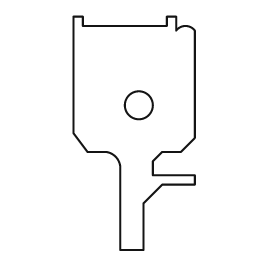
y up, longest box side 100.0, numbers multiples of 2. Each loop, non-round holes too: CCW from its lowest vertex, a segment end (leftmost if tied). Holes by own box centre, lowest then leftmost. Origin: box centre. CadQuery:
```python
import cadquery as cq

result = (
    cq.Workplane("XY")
    .moveTo(-6.0, -50.0)
    .lineTo(4.0, -50.0)
    .lineTo(4.0, -30.0)
    .lineTo(12.0, -22.0)
    .lineTo(26.0, -22.0)
    .lineTo(26.0, -18.0)
    .lineTo(8.0, -18.0)
    .lineTo(8.0, -12.0)
    .lineTo(12.0, -8.0)
    .lineTo(20.0, -8.0)
    .lineTo(26.0, -2.0)
    .lineTo(26.0, 44.0)
    .threePointArc((22.0, 46.0), (18.0, 44.0))
    .lineTo(18.0, 50.0)
    .lineTo(14.0, 50.0)
    .lineTo(14.0, 46.0)
    .lineTo(-22.0, 46.0)
    .lineTo(-22.0, 50.0)
    .lineTo(-26.0, 50.0)
    .lineTo(-26.0, 0.0)
    .lineTo(-20.0, -8.0)
    .lineTo(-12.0, -8.0)
    .threePointArc((-8.0, -10.0), (-6.0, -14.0))
    .close()
    .moveTo(2.0, 12.0)
    .circle(6.0)
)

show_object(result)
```